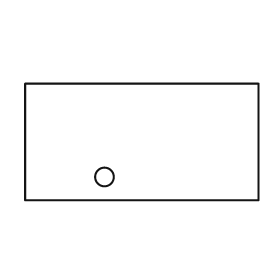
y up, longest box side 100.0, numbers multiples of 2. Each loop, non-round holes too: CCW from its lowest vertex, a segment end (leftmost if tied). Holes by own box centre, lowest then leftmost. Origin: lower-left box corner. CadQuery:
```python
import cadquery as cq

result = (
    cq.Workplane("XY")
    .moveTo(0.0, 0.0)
    .lineTo(100.0, 0.0)
    .lineTo(100.0, 50.0)
    .lineTo(0.0, 50.0)
    .close()
    .moveTo(34.0, 10.0)
    .circle(4.0)
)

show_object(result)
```